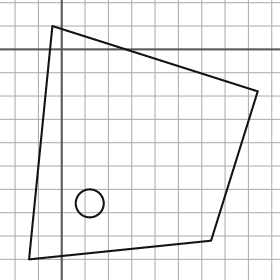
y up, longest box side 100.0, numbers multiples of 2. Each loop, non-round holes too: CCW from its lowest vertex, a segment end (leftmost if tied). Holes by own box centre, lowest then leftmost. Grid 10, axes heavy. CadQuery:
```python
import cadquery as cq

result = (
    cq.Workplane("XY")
    .moveTo(-14.0, -90.0)
    .lineTo(64.0, -82.0)
    .lineTo(84.0, -18.0)
    .lineTo(-4.0, 10.0)
    .close()
    .moveTo(12.0, -66.0)
    .circle(6.0)
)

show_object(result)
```